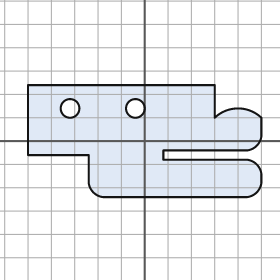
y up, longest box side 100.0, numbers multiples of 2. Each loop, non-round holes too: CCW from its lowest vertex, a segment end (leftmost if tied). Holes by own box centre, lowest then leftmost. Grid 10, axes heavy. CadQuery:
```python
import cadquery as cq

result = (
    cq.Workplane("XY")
    .moveTo(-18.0, -24.0)
    .lineTo(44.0, -24.0)
    .threePointArc((48.0, -22.0), (50.0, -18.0))
    .lineTo(50.0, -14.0)
    .threePointArc((48.0, -10.0), (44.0, -8.0))
    .lineTo(8.0, -8.0)
    .lineTo(8.0, -4.0)
    .lineTo(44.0, -4.0)
    .threePointArc((48.0, -2.0), (50.0, 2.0))
    .lineTo(50.0, 10.0)
    .threePointArc((40.0, 14.0), (30.0, 10.0))
    .lineTo(30.0, 24.0)
    .lineTo(-50.0, 24.0)
    .lineTo(-50.0, -6.0)
    .lineTo(-24.0, -6.0)
    .lineTo(-24.0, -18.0)
    .threePointArc((-22.0, -22.0), (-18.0, -24.0))
    .close()
    .moveTo(-32.0, 14.0)
    .circle(4.0)
    .moveTo(-4.0, 14.0)
    .circle(4.0)
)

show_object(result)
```